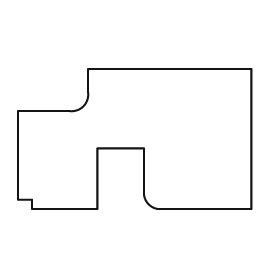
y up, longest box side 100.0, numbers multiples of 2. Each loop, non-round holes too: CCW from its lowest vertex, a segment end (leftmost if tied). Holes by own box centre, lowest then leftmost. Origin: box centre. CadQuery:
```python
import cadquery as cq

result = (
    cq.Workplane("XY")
    .moveTo(-44.0, -30.0)
    .lineTo(-16.0, -30.0)
    .lineTo(-16.0, -4.0)
    .lineTo(4.0, -4.0)
    .lineTo(4.0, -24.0)
    .threePointArc((6.0, -28.0), (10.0, -30.0))
    .lineTo(50.0, -30.0)
    .lineTo(50.0, 30.0)
    .lineTo(-20.0, 30.0)
    .lineTo(-20.0, 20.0)
    .threePointArc((-22.0, 14.0), (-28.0, 12.0))
    .lineTo(-50.0, 12.0)
    .lineTo(-50.0, -26.0)
    .lineTo(-44.0, -26.0)
    .close()
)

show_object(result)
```